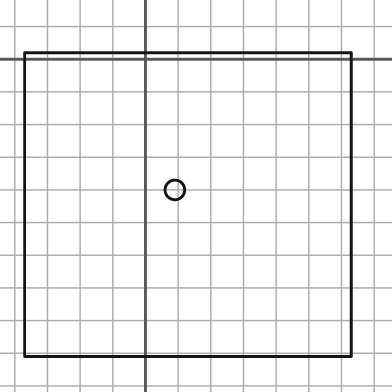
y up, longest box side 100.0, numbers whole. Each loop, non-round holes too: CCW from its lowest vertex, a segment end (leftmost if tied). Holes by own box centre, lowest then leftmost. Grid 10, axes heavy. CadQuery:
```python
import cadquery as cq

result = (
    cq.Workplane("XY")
    .moveTo(-37.0, -91.0)
    .lineTo(63.0, -91.0)
    .lineTo(63.0, 2.0)
    .lineTo(-37.0, 2.0)
    .close()
    .moveTo(9.0, -40.0)
    .circle(3.0)
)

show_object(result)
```